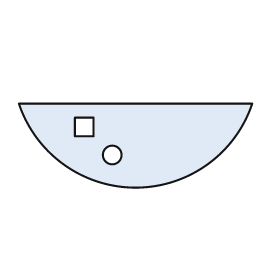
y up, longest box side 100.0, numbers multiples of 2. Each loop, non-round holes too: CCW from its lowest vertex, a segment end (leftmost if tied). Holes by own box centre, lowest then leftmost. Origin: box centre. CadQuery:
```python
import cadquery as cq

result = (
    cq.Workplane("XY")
    .moveTo(-50.0, 18.0)
    .threePointArc((0.0, -18.0), (50.0, 18.0))
    .close()
    .moveTo(-10.0, -4.0)
    .circle(4.0)
    .moveTo(-26.0, 4.0)
    .lineTo(-18.0, 4.0)
    .lineTo(-18.0, 12.0)
    .lineTo(-26.0, 12.0)
    .close()
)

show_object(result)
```